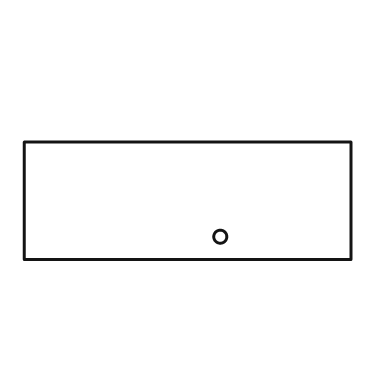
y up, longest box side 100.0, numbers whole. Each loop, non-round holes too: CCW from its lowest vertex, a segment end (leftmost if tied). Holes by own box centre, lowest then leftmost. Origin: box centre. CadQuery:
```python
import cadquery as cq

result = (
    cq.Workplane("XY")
    .moveTo(-50.0, -18.0)
    .lineTo(50.0, -18.0)
    .lineTo(50.0, 18.0)
    .lineTo(-50.0, 18.0)
    .close()
    .moveTo(10.0, -11.0)
    .circle(2.0)
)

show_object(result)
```